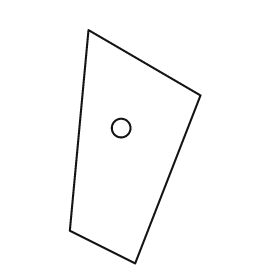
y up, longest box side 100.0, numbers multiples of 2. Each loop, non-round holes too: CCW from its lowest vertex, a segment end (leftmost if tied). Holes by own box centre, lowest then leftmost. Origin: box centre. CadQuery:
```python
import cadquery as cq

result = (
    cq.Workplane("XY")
    .moveTo(0.0, -50.0)
    .lineTo(28.0, 22.0)
    .lineTo(-20.0, 50.0)
    .lineTo(-28.0, -36.0)
    .close()
    .moveTo(-6.0, 8.0)
    .circle(4.0)
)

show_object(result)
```